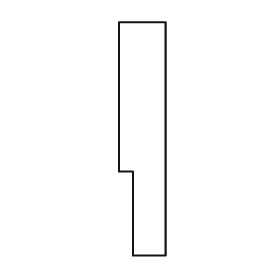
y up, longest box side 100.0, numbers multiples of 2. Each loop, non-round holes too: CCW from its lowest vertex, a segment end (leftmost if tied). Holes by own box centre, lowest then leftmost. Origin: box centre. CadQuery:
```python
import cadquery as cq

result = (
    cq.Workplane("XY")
    .moveTo(-4.0, -50.0)
    .lineTo(10.0, -50.0)
    .lineTo(10.0, 50.0)
    .lineTo(-10.0, 50.0)
    .lineTo(-10.0, -14.0)
    .lineTo(-4.0, -14.0)
    .close()
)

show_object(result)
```